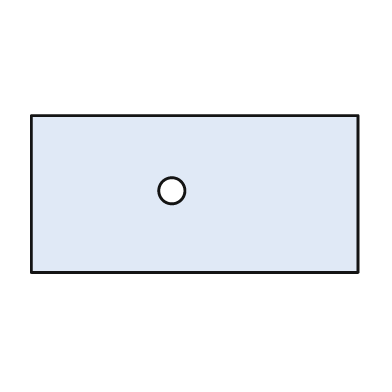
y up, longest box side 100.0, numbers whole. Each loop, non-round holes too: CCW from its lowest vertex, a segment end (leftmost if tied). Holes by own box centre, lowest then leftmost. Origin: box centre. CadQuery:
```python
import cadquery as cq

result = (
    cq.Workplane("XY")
    .moveTo(-50.0, -24.0)
    .lineTo(50.0, -24.0)
    .lineTo(50.0, 24.0)
    .lineTo(-50.0, 24.0)
    .close()
    .moveTo(-7.0, 1.0)
    .circle(4.0)
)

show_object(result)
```